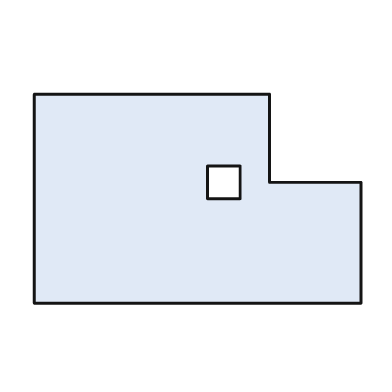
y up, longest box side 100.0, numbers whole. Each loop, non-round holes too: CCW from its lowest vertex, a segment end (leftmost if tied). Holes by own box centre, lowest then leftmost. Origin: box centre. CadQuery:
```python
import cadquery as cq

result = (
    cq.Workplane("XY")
    .moveTo(-50.0, -32.0)
    .lineTo(50.0, -32.0)
    .lineTo(50.0, 5.0)
    .lineTo(22.0, 5.0)
    .lineTo(22.0, 32.0)
    .lineTo(-50.0, 32.0)
    .close()
    .moveTo(3.0, 0.0)
    .lineTo(13.0, 0.0)
    .lineTo(13.0, 10.0)
    .lineTo(3.0, 10.0)
    .close()
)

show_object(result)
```